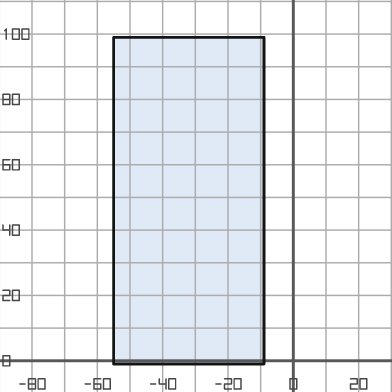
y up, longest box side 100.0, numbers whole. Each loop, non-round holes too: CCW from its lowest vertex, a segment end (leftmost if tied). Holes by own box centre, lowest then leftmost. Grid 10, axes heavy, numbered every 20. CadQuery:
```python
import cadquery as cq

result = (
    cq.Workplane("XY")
    .moveTo(-55.0, -1.0)
    .lineTo(-9.0, -1.0)
    .lineTo(-9.0, 99.0)
    .lineTo(-55.0, 99.0)
    .close()
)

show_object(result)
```